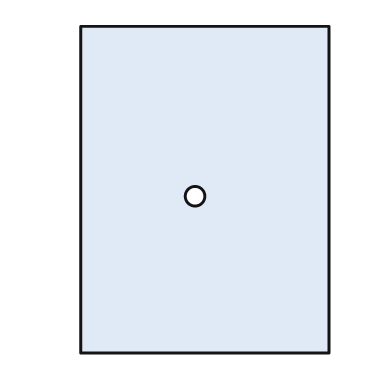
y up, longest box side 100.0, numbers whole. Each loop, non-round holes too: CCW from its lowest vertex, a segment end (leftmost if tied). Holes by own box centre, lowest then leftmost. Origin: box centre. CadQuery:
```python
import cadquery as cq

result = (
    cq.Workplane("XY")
    .moveTo(-38.0, -50.0)
    .lineTo(38.0, -50.0)
    .lineTo(38.0, 50.0)
    .lineTo(-38.0, 50.0)
    .close()
    .moveTo(-3.0, -2.0)
    .circle(3.0)
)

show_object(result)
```